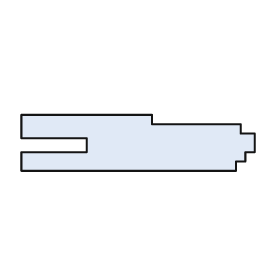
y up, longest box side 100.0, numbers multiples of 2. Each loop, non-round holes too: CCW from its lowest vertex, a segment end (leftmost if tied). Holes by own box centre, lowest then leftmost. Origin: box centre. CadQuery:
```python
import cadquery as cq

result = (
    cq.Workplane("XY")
    .moveTo(-50.0, -12.0)
    .lineTo(42.0, -12.0)
    .lineTo(42.0, -8.0)
    .lineTo(46.0, -8.0)
    .lineTo(46.0, -4.0)
    .lineTo(50.0, -4.0)
    .lineTo(50.0, 4.0)
    .lineTo(44.0, 4.0)
    .lineTo(44.0, 8.0)
    .lineTo(6.0, 8.0)
    .lineTo(6.0, 12.0)
    .lineTo(-50.0, 12.0)
    .lineTo(-50.0, 2.0)
    .lineTo(-22.0, 2.0)
    .lineTo(-22.0, -4.0)
    .lineTo(-50.0, -4.0)
    .close()
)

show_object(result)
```